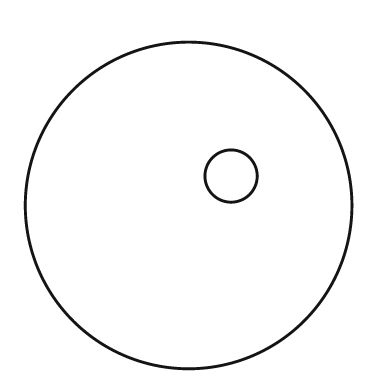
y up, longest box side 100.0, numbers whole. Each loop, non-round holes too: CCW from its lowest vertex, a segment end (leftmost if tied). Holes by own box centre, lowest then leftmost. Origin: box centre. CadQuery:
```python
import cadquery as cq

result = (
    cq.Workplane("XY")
    .moveTo(0.0, 0.0)
    .circle(50.0)
    .moveTo(13.0, 9.0)
    .circle(8.0)
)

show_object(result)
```